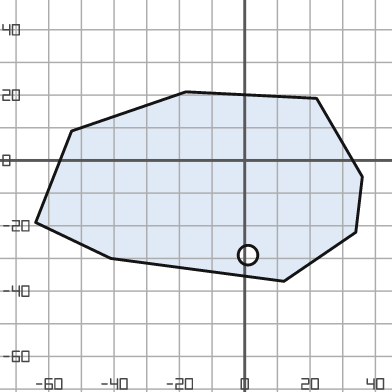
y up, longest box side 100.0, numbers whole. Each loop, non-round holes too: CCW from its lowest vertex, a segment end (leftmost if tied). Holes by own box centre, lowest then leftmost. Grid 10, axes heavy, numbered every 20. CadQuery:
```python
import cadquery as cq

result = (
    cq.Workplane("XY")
    .moveTo(12.0, -37.0)
    .lineTo(34.0, -22.0)
    .lineTo(36.0, -5.0)
    .lineTo(22.0, 19.0)
    .lineTo(-18.0, 21.0)
    .lineTo(-53.0, 9.0)
    .lineTo(-64.0, -19.0)
    .lineTo(-41.0, -30.0)
    .close()
    .moveTo(1.0, -29.0)
    .circle(3.0)
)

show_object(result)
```